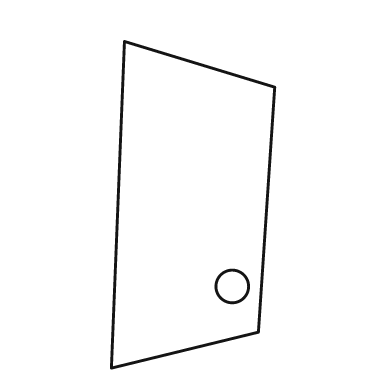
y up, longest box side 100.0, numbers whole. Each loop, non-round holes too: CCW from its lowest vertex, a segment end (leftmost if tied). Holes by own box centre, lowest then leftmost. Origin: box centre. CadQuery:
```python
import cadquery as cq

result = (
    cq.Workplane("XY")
    .moveTo(-25.0, -50.0)
    .lineTo(20.0, -39.0)
    .lineTo(25.0, 36.0)
    .lineTo(-21.0, 50.0)
    .close()
    .moveTo(12.0, -25.0)
    .circle(5.0)
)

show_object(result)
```